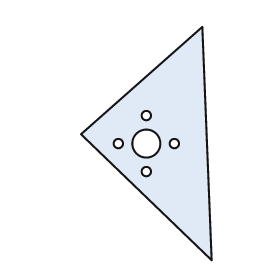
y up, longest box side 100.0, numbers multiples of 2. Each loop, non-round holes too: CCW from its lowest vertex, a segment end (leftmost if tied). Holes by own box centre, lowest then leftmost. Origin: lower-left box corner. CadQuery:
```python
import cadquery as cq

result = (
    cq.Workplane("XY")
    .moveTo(56.0, 0.0)
    .lineTo(52.0, 100.0)
    .lineTo(0.0, 54.0)
    .close()
    .moveTo(28.0, 38.0)
    .circle(2.0)
    .moveTo(16.0, 50.0)
    .circle(2.0)
    .moveTo(28.0, 50.0)
    .circle(6.0)
    .moveTo(40.0, 50.0)
    .circle(2.0)
    .moveTo(28.0, 62.0)
    .circle(2.0)
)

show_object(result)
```